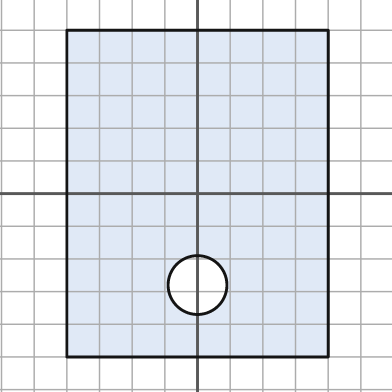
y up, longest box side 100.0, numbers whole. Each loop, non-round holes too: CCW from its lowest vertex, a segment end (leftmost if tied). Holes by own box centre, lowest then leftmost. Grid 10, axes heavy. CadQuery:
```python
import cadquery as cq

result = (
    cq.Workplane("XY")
    .moveTo(-40.0, -50.0)
    .lineTo(40.0, -50.0)
    .lineTo(40.0, 50.0)
    .lineTo(-40.0, 50.0)
    .close()
    .moveTo(0.0, -28.0)
    .circle(9.0)
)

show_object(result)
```